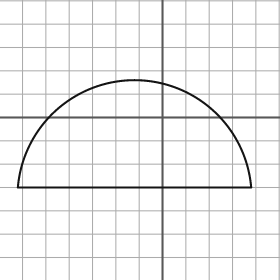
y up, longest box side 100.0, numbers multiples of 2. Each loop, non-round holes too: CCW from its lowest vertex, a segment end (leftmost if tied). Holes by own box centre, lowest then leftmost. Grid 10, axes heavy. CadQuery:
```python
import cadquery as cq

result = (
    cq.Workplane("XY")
    .moveTo(-62.0, -30.0)
    .lineTo(38.0, -30.0)
    .threePointArc((-12.0, 16.0), (-62.0, -30.0))
    .close()
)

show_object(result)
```